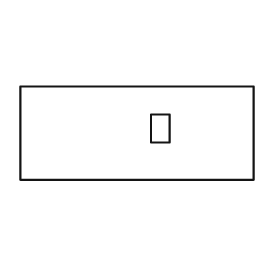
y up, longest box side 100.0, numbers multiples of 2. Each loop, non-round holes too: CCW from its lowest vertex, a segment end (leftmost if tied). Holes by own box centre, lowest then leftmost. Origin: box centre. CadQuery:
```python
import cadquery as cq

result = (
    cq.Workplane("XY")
    .moveTo(-50.0, -20.0)
    .lineTo(50.0, -20.0)
    .lineTo(50.0, 20.0)
    .lineTo(-50.0, 20.0)
    .close()
    .moveTo(6.0, -4.0)
    .lineTo(14.0, -4.0)
    .lineTo(14.0, 8.0)
    .lineTo(6.0, 8.0)
    .close()
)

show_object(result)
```